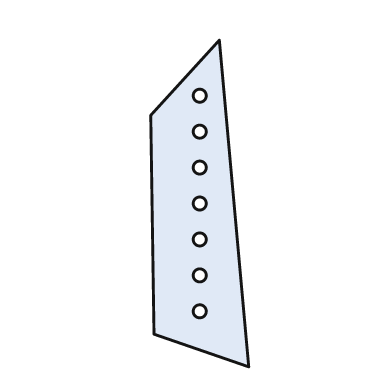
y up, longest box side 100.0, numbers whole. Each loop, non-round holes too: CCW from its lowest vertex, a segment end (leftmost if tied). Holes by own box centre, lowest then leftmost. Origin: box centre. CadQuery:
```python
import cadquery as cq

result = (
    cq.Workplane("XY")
    .moveTo(15.0, -50.0)
    .lineTo(6.0, 50.0)
    .lineTo(-15.0, 27.0)
    .lineTo(-14.0, -40.0)
    .close()
    .moveTo(0.0, -33.0)
    .circle(2.0)
    .moveTo(0.0, -22.0)
    .circle(2.0)
    .moveTo(0.0, -11.0)
    .circle(2.0)
    .moveTo(0.0, 0.0)
    .circle(2.0)
    .moveTo(0.0, 11.0)
    .circle(2.0)
    .moveTo(0.0, 22.0)
    .circle(2.0)
    .moveTo(0.0, 33.0)
    .circle(2.0)
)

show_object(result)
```